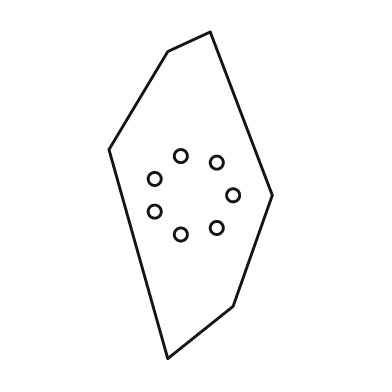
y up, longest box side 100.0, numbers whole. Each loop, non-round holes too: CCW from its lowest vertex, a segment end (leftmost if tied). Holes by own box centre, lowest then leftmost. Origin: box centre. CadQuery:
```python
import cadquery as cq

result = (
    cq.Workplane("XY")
    .moveTo(-7.0, -50.0)
    .lineTo(13.0, -34.0)
    .lineTo(25.0, 0.0)
    .lineTo(6.0, 50.0)
    .lineTo(-7.0, 44.0)
    .lineTo(-25.0, 14.0)
    .close()
    .moveTo(-3.0, -12.0)
    .circle(2.0)
    .moveTo(8.0, -10.0)
    .circle(2.0)
    .moveTo(-11.0, -5.0)
    .circle(2.0)
    .moveTo(13.0, 0.0)
    .circle(2.0)
    .moveTo(-11.0, 5.0)
    .circle(2.0)
    .moveTo(8.0, 10.0)
    .circle(2.0)
    .moveTo(-3.0, 12.0)
    .circle(2.0)
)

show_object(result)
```